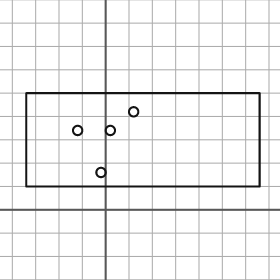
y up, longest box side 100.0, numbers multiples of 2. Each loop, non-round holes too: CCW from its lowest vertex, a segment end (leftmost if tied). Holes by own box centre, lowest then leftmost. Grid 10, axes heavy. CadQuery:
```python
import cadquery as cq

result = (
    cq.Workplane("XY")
    .moveTo(-34.0, 10.0)
    .lineTo(66.0, 10.0)
    .lineTo(66.0, 50.0)
    .lineTo(-34.0, 50.0)
    .close()
    .moveTo(-2.0, 16.0)
    .circle(2.0)
    .moveTo(-12.0, 34.0)
    .circle(2.0)
    .moveTo(2.0, 34.0)
    .circle(2.0)
    .moveTo(12.0, 42.0)
    .circle(2.0)
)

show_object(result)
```